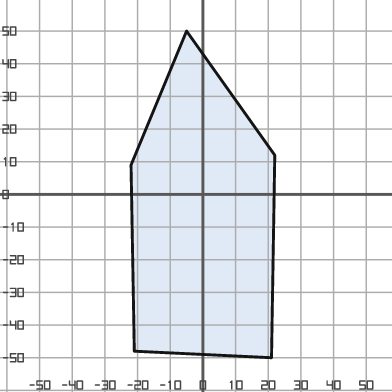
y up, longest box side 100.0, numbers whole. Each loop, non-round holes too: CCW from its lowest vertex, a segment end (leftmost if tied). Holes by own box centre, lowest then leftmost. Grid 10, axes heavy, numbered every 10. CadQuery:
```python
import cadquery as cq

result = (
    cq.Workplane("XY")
    .moveTo(21.0, -50.0)
    .lineTo(22.0, 12.0)
    .lineTo(-5.0, 50.0)
    .lineTo(-22.0, 9.0)
    .lineTo(-21.0, -48.0)
    .close()
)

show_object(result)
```